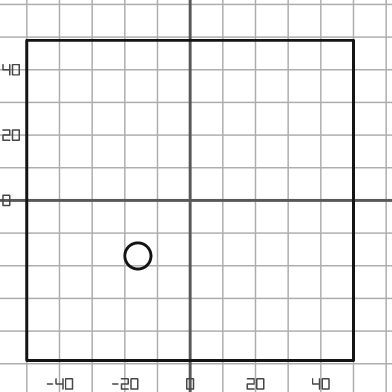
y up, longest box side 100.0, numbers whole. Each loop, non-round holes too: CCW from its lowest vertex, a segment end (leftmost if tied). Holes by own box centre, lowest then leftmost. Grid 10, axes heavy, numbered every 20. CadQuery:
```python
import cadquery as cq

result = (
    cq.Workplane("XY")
    .moveTo(-50.0, -49.0)
    .lineTo(50.0, -49.0)
    .lineTo(50.0, 49.0)
    .lineTo(-50.0, 49.0)
    .close()
    .moveTo(-16.0, -17.0)
    .circle(4.0)
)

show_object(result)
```